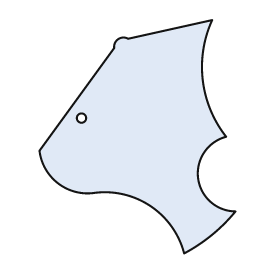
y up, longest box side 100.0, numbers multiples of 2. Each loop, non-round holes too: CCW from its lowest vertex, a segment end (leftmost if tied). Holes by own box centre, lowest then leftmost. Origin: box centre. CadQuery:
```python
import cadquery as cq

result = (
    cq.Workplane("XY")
    .moveTo(20.0, -50.0)
    .threePointArc((32.0, -42.0), (42.0, -32.0))
    .threePointArc((26.0, -18.0), (38.0, 0.0))
    .threePointArc((28.0, 24.0), (32.0, 50.0))
    .lineTo(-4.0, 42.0)
    .threePointArc((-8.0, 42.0), (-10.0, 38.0))
    .lineTo(-42.0, -6.0)
    .threePointArc((-34.0, -20.0), (-18.0, -24.0))
    .threePointArc((6.0, -30.0), (20.0, -50.0))
    .close()
    .moveTo(-24.0, 8.0)
    .circle(2.0)
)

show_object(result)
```